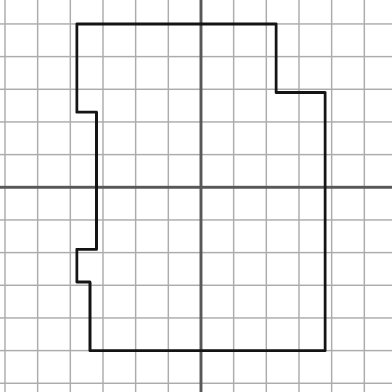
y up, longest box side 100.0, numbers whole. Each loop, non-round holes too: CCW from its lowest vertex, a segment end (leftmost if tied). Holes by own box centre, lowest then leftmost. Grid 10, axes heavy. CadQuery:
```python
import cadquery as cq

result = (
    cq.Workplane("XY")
    .moveTo(-34.0, -50.0)
    .lineTo(38.0, -50.0)
    .lineTo(38.0, 29.0)
    .lineTo(23.0, 29.0)
    .lineTo(23.0, 50.0)
    .lineTo(-38.0, 50.0)
    .lineTo(-38.0, 23.0)
    .lineTo(-32.0, 23.0)
    .lineTo(-32.0, -19.0)
    .lineTo(-38.0, -19.0)
    .lineTo(-38.0, -29.0)
    .lineTo(-34.0, -29.0)
    .close()
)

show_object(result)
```